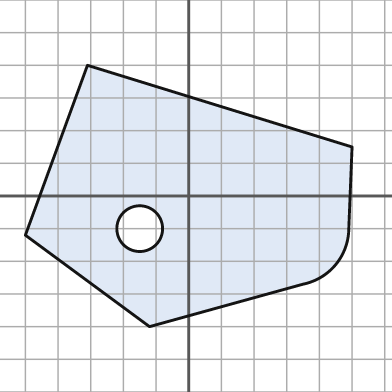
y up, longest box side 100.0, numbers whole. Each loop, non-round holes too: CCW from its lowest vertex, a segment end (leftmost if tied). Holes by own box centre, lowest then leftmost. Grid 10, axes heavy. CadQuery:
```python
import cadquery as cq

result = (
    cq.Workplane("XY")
    .moveTo(-12.0, -40.0)
    .lineTo(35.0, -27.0)
    .threePointArc((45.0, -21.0), (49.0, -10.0))
    .lineTo(50.0, 15.0)
    .lineTo(-31.0, 40.0)
    .lineTo(-50.0, -12.0)
    .close()
    .moveTo(-15.0, -10.0)
    .circle(7.0)
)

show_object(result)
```